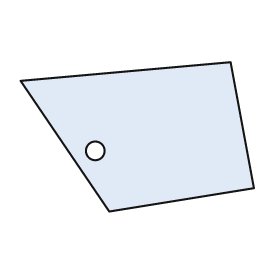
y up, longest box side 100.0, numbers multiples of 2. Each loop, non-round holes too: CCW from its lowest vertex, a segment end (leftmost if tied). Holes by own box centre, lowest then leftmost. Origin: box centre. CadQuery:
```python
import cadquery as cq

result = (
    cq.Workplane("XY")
    .moveTo(-12.0, -32.0)
    .lineTo(50.0, -22.0)
    .lineTo(40.0, 32.0)
    .lineTo(-50.0, 24.0)
    .close()
    .moveTo(-18.0, -6.0)
    .circle(4.0)
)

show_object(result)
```